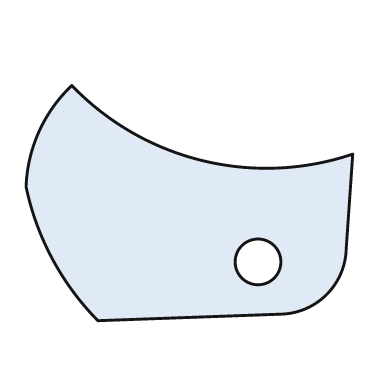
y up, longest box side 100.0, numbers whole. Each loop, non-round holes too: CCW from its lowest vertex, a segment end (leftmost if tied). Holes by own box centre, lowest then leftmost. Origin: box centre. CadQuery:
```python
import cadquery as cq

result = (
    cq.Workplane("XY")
    .moveTo(-28.0, -36.0)
    .lineTo(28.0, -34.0)
    .threePointArc((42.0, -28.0), (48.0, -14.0))
    .lineTo(50.0, 15.0)
    .threePointArc((4.0, 13.0), (-36.0, 36.0))
    .threePointArc((-46.0, 22.0), (-50.0, 5.0))
    .threePointArc((-42.0, -17.0), (-28.0, -36.0))
    .close()
    .moveTo(21.0, -18.0)
    .circle(7.0)
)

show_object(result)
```